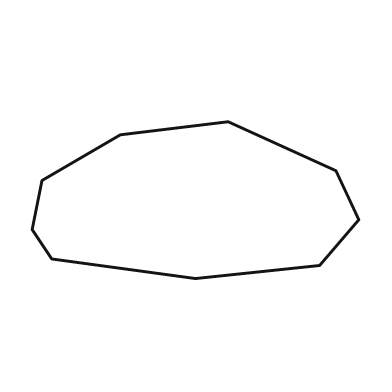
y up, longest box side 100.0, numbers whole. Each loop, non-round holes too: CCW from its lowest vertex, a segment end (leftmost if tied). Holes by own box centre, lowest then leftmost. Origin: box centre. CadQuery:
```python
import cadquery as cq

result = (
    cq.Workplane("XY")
    .moveTo(0.0, -24.0)
    .lineTo(38.0, -20.0)
    .lineTo(50.0, -6.0)
    .lineTo(43.0, 9.0)
    .lineTo(10.0, 24.0)
    .lineTo(-23.0, 20.0)
    .lineTo(-47.0, 6.0)
    .lineTo(-50.0, -9.0)
    .lineTo(-44.0, -18.0)
    .close()
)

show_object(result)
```